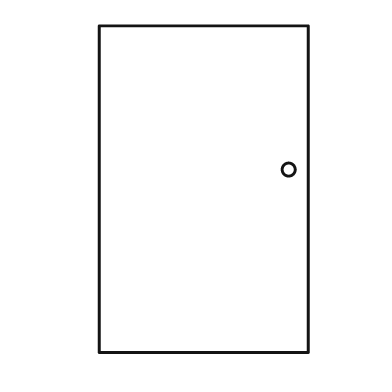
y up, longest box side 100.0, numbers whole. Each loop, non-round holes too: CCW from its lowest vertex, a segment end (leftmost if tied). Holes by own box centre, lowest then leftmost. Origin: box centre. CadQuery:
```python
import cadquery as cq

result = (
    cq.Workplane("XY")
    .moveTo(-32.0, -50.0)
    .lineTo(32.0, -50.0)
    .lineTo(32.0, 50.0)
    .lineTo(-32.0, 50.0)
    .close()
    .moveTo(26.0, 6.0)
    .circle(2.0)
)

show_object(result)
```